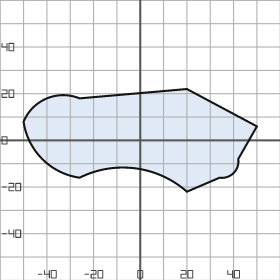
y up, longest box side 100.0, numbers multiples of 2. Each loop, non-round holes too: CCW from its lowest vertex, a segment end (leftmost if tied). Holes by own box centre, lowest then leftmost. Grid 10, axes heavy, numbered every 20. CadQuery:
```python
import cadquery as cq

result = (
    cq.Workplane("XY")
    .moveTo(20.0, -22.0)
    .lineTo(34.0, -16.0)
    .threePointArc((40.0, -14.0), (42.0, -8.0))
    .lineTo(50.0, 6.0)
    .lineTo(20.0, 22.0)
    .lineTo(-26.0, 18.0)
    .threePointArc((-40.0, 18.0), (-50.0, 8.0))
    .threePointArc((-42.0, -8.0), (-26.0, -16.0))
    .threePointArc((-2.0, -12.0), (20.0, -22.0))
    .close()
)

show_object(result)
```